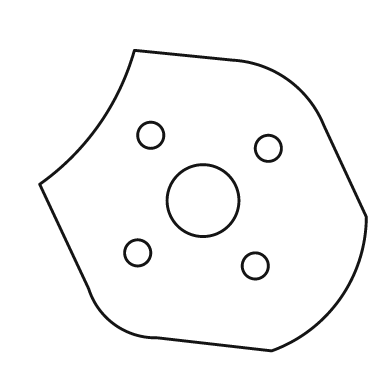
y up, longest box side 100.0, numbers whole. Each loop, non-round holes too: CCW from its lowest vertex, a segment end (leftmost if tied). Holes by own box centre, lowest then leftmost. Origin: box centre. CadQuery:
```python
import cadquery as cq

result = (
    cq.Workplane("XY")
    .moveTo(21.0, -46.0)
    .threePointArc((42.0, -30.0), (50.0, -5.0))
    .lineTo(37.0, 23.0)
    .threePointArc((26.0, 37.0), (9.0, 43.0))
    .lineTo(-21.0, 46.0)
    .threePointArc((-32.0, 23.0), (-50.0, 5.0))
    .lineTo(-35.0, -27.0)
    .threePointArc((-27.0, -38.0), (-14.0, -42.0))
    .close()
    .moveTo(16.0, -20.0)
    .circle(4.0)
    .moveTo(-20.0, -16.0)
    .circle(4.0)
    .moveTo(0.0, 0.0)
    .circle(11.0)
    .moveTo(20.0, 16.0)
    .circle(4.0)
    .moveTo(-16.0, 20.0)
    .circle(4.0)
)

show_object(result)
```